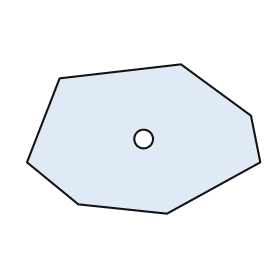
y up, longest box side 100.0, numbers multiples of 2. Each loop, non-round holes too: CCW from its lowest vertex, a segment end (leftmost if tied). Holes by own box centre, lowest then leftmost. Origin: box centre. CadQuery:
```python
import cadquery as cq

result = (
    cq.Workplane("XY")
    .moveTo(10.0, -32.0)
    .lineTo(50.0, -10.0)
    .lineTo(46.0, 10.0)
    .lineTo(16.0, 32.0)
    .lineTo(-36.0, 26.0)
    .lineTo(-50.0, -10.0)
    .lineTo(-28.0, -28.0)
    .close()
    .moveTo(0.0, 0.0)
    .circle(4.0)
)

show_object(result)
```